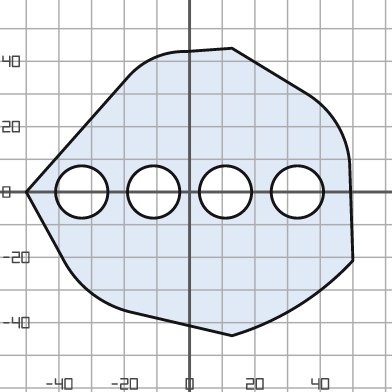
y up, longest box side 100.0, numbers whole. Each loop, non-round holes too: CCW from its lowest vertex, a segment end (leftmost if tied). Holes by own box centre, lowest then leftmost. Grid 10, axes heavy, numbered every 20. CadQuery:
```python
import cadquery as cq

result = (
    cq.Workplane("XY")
    .moveTo(13.0, -44.0)
    .threePointArc((33.0, -35.0), (50.0, -21.0))
    .lineTo(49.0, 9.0)
    .threePointArc((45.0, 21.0), (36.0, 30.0))
    .lineTo(13.0, 44.0)
    .lineTo(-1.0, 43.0)
    .threePointArc((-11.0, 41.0), (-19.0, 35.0))
    .lineTo(-50.0, 0.0)
    .lineTo(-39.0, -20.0)
    .threePointArc((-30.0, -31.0), (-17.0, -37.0))
    .close()
    .moveTo(-33.0, 0.0)
    .circle(8.0)
    .moveTo(-11.0, 0.0)
    .circle(8.0)
    .moveTo(11.0, 0.0)
    .circle(8.0)
    .moveTo(33.0, 0.0)
    .circle(8.0)
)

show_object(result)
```